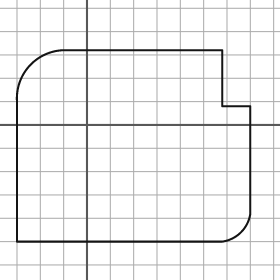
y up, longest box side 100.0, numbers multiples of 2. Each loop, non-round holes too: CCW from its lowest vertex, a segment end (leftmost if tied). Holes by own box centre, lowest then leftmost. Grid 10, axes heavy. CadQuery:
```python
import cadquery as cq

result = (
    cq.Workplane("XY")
    .moveTo(-30.0, -50.0)
    .lineTo(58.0, -50.0)
    .threePointArc((66.0, -46.0), (70.0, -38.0))
    .lineTo(70.0, 8.0)
    .lineTo(58.0, 8.0)
    .lineTo(58.0, 32.0)
    .lineTo(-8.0, 32.0)
    .threePointArc((-24.0, 26.0), (-30.0, 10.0))
    .close()
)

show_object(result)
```